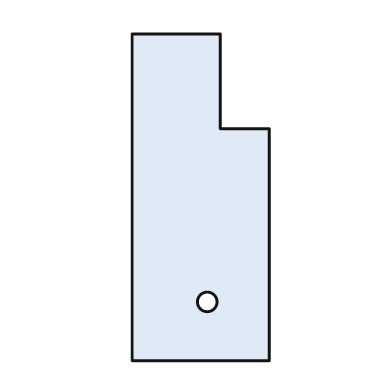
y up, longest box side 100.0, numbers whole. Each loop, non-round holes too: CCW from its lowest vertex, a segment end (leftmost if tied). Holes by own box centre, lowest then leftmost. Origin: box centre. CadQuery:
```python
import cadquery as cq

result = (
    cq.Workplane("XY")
    .moveTo(-21.0, -50.0)
    .lineTo(21.0, -50.0)
    .lineTo(21.0, 21.0)
    .lineTo(6.0, 21.0)
    .lineTo(6.0, 50.0)
    .lineTo(-21.0, 50.0)
    .close()
    .moveTo(2.0, -32.0)
    .circle(3.0)
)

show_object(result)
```